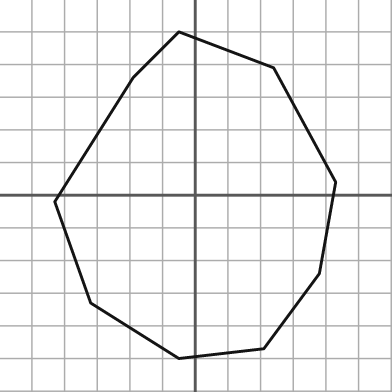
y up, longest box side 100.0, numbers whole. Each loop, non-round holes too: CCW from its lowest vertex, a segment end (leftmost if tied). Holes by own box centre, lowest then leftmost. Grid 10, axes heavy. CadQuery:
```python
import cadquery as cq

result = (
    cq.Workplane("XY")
    .moveTo(-5.0, -50.0)
    .lineTo(21.0, -47.0)
    .lineTo(38.0, -24.0)
    .lineTo(43.0, 4.0)
    .lineTo(24.0, 39.0)
    .lineTo(-5.0, 50.0)
    .lineTo(-19.0, 36.0)
    .lineTo(-43.0, -2.0)
    .lineTo(-32.0, -33.0)
    .close()
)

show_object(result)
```